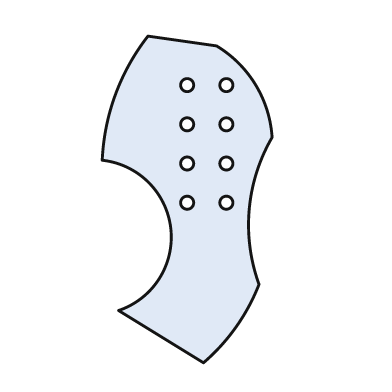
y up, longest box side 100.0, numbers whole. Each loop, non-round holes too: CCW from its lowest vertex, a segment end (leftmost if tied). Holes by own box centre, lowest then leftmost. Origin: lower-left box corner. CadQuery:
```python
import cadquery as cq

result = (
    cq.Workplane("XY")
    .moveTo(31.0, 0.0)
    .threePointArc((41.0, 11.0), (48.0, 24.0))
    .threePointArc((45.0, 47.0), (52.0, 69.0))
    .threePointArc((47.0, 85.0), (35.0, 97.0))
    .lineTo(14.0, 100.0)
    .threePointArc((4.0, 82.0), (0.0, 62.0))
    .threePointArc((21.0, 41.0), (5.0, 16.0))
    .close()
    .moveTo(26.0, 49.0)
    .circle(2.0)
    .moveTo(38.0, 49.0)
    .circle(2.0)
    .moveTo(26.0, 61.0)
    .circle(2.0)
    .moveTo(38.0, 61.0)
    .circle(2.0)
    .moveTo(26.0, 73.0)
    .circle(2.0)
    .moveTo(38.0, 73.0)
    .circle(2.0)
    .moveTo(26.0, 85.0)
    .circle(2.0)
    .moveTo(38.0, 85.0)
    .circle(2.0)
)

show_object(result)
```